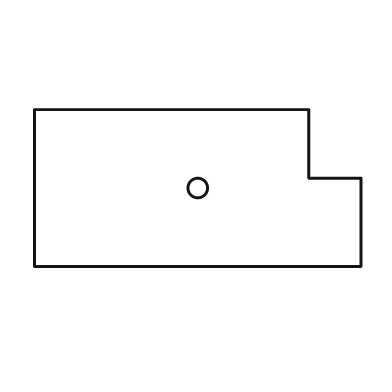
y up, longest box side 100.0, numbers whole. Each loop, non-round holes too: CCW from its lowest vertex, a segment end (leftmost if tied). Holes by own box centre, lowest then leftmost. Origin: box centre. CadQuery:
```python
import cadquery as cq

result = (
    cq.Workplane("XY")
    .moveTo(-50.0, -24.0)
    .lineTo(50.0, -24.0)
    .lineTo(50.0, 3.0)
    .lineTo(34.0, 3.0)
    .lineTo(34.0, 24.0)
    .lineTo(-50.0, 24.0)
    .close()
    .moveTo(0.0, 0.0)
    .circle(3.0)
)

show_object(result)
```